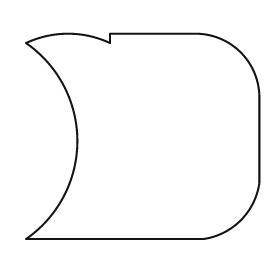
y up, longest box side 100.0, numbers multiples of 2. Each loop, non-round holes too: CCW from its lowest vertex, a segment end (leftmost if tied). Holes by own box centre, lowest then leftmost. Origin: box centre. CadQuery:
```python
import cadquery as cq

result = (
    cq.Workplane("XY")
    .moveTo(-50.0, -44.0)
    .lineTo(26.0, -44.0)
    .threePointArc((42.0, -36.0), (50.0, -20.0))
    .lineTo(50.0, 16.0)
    .threePointArc((42.0, 36.0), (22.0, 44.0))
    .lineTo(-14.0, 44.0)
    .lineTo(-14.0, 40.0)
    .threePointArc((-32.0, 44.0), (-50.0, 40.0))
    .threePointArc((-28.0, -2.0), (-50.0, -44.0))
    .close()
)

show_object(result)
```